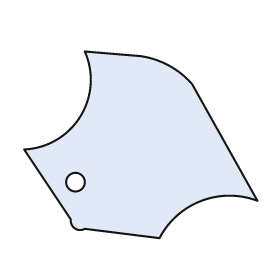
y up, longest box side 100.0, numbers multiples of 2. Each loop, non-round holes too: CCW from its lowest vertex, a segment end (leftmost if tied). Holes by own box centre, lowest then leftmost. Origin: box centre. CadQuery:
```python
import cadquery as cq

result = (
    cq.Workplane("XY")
    .moveTo(8.0, -40.0)
    .threePointArc((26.0, -24.0), (50.0, -24.0))
    .lineTo(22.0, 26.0)
    .threePointArc((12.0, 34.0), (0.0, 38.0))
    .lineTo(-24.0, 40.0)
    .threePointArc((-26.0, 12.0), (-50.0, -2.0))
    .lineTo(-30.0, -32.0)
    .threePointArc((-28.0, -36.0), (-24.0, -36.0))
    .close()
    .moveTo(-28.0, -16.0)
    .circle(4.0)
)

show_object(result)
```